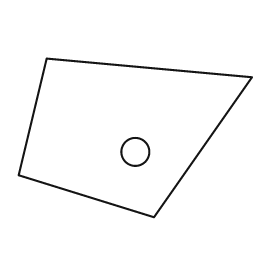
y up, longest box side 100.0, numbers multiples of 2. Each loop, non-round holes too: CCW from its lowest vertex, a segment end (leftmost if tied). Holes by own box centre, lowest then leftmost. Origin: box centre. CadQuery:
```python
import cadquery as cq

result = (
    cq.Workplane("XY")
    .moveTo(8.0, -34.0)
    .lineTo(50.0, 26.0)
    .lineTo(-38.0, 34.0)
    .lineTo(-50.0, -16.0)
    .close()
    .moveTo(0.0, -6.0)
    .circle(6.0)
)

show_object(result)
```